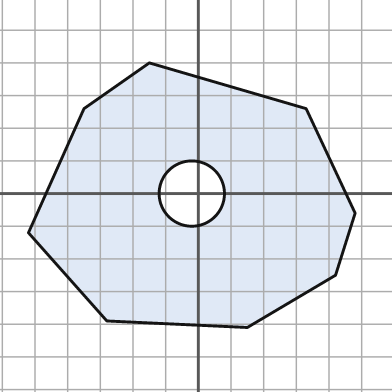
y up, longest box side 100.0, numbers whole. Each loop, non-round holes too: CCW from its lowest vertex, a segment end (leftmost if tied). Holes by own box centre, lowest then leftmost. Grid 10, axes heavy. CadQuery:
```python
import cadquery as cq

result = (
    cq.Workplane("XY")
    .moveTo(15.0, -41.0)
    .lineTo(42.0, -25.0)
    .lineTo(48.0, -6.0)
    .lineTo(33.0, 26.0)
    .lineTo(-15.0, 40.0)
    .lineTo(-35.0, 26.0)
    .lineTo(-52.0, -12.0)
    .lineTo(-28.0, -39.0)
    .close()
    .moveTo(-2.0, 0.0)
    .circle(10.0)
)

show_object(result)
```